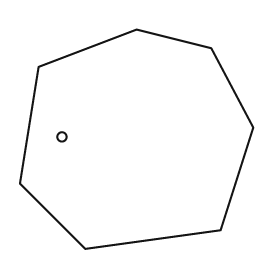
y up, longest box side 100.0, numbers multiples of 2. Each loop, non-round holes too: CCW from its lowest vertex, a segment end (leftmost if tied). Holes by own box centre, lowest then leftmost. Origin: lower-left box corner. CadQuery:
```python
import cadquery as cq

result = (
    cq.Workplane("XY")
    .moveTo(28.0, 0.0)
    .lineTo(86.0, 8.0)
    .lineTo(100.0, 52.0)
    .lineTo(82.0, 86.0)
    .lineTo(50.0, 94.0)
    .lineTo(8.0, 78.0)
    .lineTo(0.0, 28.0)
    .close()
    .moveTo(18.0, 48.0)
    .circle(2.0)
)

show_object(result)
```